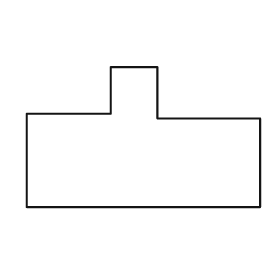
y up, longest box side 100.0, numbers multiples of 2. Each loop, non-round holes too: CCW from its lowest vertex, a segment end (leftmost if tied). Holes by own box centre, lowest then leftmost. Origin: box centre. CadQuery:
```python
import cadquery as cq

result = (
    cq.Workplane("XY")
    .moveTo(-50.0, -30.0)
    .lineTo(50.0, -30.0)
    .lineTo(50.0, 8.0)
    .lineTo(6.0, 8.0)
    .lineTo(6.0, 30.0)
    .lineTo(-14.0, 30.0)
    .lineTo(-14.0, 10.0)
    .lineTo(-50.0, 10.0)
    .close()
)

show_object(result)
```